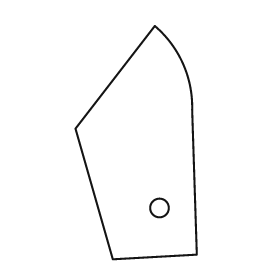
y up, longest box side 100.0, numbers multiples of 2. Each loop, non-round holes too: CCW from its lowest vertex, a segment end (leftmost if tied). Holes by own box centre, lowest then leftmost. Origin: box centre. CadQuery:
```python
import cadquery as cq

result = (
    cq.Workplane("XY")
    .moveTo(-10.0, -50.0)
    .lineTo(26.0, -48.0)
    .lineTo(24.0, 14.0)
    .threePointArc((20.0, 34.0), (8.0, 50.0))
    .lineTo(-26.0, 6.0)
    .close()
    .moveTo(10.0, -28.0)
    .circle(4.0)
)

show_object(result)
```